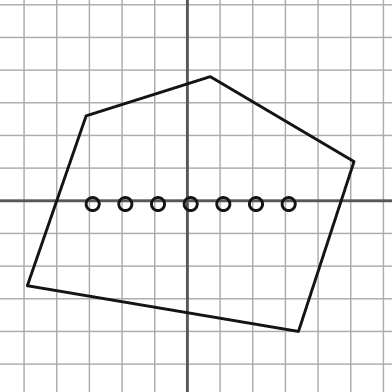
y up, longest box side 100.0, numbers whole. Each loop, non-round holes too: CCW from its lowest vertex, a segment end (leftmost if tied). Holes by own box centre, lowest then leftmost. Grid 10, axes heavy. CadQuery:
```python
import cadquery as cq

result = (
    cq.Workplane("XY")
    .moveTo(34.0, -40.0)
    .lineTo(51.0, 12.0)
    .lineTo(7.0, 38.0)
    .lineTo(-31.0, 26.0)
    .lineTo(-49.0, -26.0)
    .close()
    .moveTo(-29.0, -1.0)
    .circle(2.0)
    .moveTo(-19.0, -1.0)
    .circle(2.0)
    .moveTo(-9.0, -1.0)
    .circle(2.0)
    .moveTo(1.0, -1.0)
    .circle(2.0)
    .moveTo(11.0, -1.0)
    .circle(2.0)
    .moveTo(21.0, -1.0)
    .circle(2.0)
    .moveTo(31.0, -1.0)
    .circle(2.0)
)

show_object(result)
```